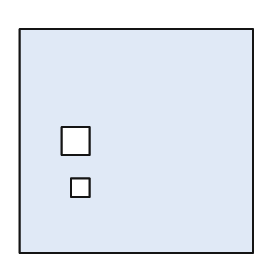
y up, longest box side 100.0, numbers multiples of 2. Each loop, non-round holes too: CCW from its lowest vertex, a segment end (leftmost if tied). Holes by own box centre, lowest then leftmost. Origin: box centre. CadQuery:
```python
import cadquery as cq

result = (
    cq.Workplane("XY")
    .moveTo(-50.0, -48.0)
    .lineTo(50.0, -48.0)
    .lineTo(50.0, 48.0)
    .lineTo(-50.0, 48.0)
    .close()
    .moveTo(-28.0, -24.0)
    .lineTo(-20.0, -24.0)
    .lineTo(-20.0, -16.0)
    .lineTo(-28.0, -16.0)
    .close()
    .moveTo(-32.0, -6.0)
    .lineTo(-20.0, -6.0)
    .lineTo(-20.0, 6.0)
    .lineTo(-32.0, 6.0)
    .close()
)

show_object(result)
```